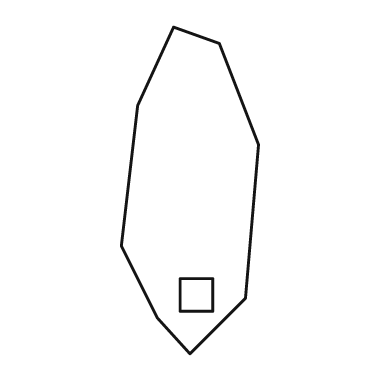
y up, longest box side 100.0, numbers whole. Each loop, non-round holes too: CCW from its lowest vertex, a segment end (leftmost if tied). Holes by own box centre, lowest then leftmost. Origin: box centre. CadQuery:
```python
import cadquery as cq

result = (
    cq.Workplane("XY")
    .moveTo(0.0, -50.0)
    .lineTo(17.0, -33.0)
    .lineTo(21.0, 14.0)
    .lineTo(9.0, 45.0)
    .lineTo(-5.0, 50.0)
    .lineTo(-16.0, 26.0)
    .lineTo(-21.0, -17.0)
    .lineTo(-10.0, -39.0)
    .close()
    .moveTo(-3.0, -37.0)
    .lineTo(7.0, -37.0)
    .lineTo(7.0, -27.0)
    .lineTo(-3.0, -27.0)
    .close()
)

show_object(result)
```